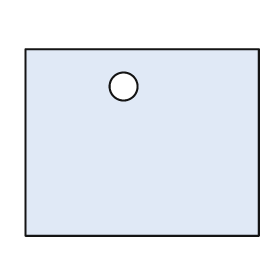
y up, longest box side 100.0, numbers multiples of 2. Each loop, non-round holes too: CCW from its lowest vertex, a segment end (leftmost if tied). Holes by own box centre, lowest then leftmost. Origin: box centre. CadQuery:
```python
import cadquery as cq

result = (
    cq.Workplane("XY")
    .moveTo(-50.0, -40.0)
    .lineTo(50.0, -40.0)
    .lineTo(50.0, 40.0)
    .lineTo(-50.0, 40.0)
    .close()
    .moveTo(-8.0, 24.0)
    .circle(6.0)
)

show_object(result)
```